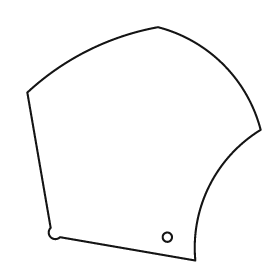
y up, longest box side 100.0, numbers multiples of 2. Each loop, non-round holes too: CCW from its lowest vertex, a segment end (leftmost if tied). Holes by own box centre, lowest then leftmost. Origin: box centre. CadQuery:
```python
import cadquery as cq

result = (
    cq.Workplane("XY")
    .moveTo(22.0, -50.0)
    .threePointArc((28.0, -18.0), (50.0, 6.0))
    .threePointArc((34.0, 34.0), (6.0, 50.0))
    .threePointArc((-24.0, 40.0), (-50.0, 22.0))
    .lineTo(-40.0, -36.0)
    .threePointArc((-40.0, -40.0), (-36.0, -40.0))
    .close()
    .moveTo(10.0, -40.0)
    .circle(2.0)
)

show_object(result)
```